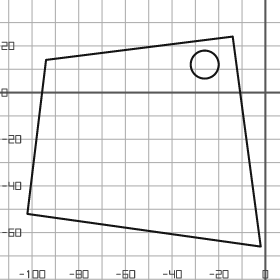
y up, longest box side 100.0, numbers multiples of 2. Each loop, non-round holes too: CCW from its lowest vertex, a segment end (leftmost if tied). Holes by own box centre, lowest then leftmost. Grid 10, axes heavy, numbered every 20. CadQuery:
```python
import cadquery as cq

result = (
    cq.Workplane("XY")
    .moveTo(-2.0, -66.0)
    .lineTo(-14.0, 24.0)
    .lineTo(-94.0, 14.0)
    .lineTo(-102.0, -52.0)
    .close()
    .moveTo(-26.0, 12.0)
    .circle(6.0)
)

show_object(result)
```